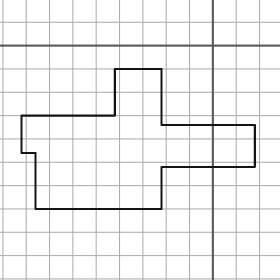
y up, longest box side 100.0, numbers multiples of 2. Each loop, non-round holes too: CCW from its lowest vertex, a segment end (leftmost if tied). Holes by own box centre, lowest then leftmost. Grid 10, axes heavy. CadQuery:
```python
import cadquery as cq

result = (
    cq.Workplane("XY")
    .moveTo(-76.0, -70.0)
    .lineTo(-22.0, -70.0)
    .lineTo(-22.0, -52.0)
    .lineTo(18.0, -52.0)
    .lineTo(18.0, -34.0)
    .lineTo(-22.0, -34.0)
    .lineTo(-22.0, -10.0)
    .lineTo(-42.0, -10.0)
    .lineTo(-42.0, -30.0)
    .lineTo(-82.0, -30.0)
    .lineTo(-82.0, -46.0)
    .lineTo(-76.0, -46.0)
    .close()
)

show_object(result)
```